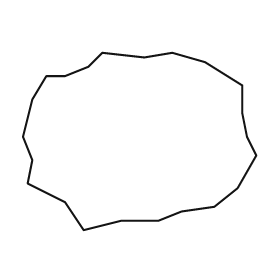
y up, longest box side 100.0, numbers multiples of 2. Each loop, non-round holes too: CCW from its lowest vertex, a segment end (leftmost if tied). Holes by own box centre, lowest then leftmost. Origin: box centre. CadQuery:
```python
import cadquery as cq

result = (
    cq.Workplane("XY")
    .moveTo(-24.0, -38.0)
    .lineTo(-8.0, -34.0)
    .lineTo(8.0, -34.0)
    .lineTo(18.0, -30.0)
    .lineTo(32.0, -28.0)
    .lineTo(42.0, -20.0)
    .lineTo(50.0, -6.0)
    .lineTo(46.0, 2.0)
    .lineTo(44.0, 12.0)
    .lineTo(44.0, 24.0)
    .lineTo(28.0, 34.0)
    .lineTo(14.0, 38.0)
    .lineTo(2.0, 36.0)
    .lineTo(-16.0, 38.0)
    .lineTo(-22.0, 32.0)
    .lineTo(-32.0, 28.0)
    .lineTo(-40.0, 28.0)
    .lineTo(-46.0, 18.0)
    .lineTo(-50.0, 2.0)
    .lineTo(-46.0, -8.0)
    .lineTo(-48.0, -18.0)
    .lineTo(-32.0, -26.0)
    .close()
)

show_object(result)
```